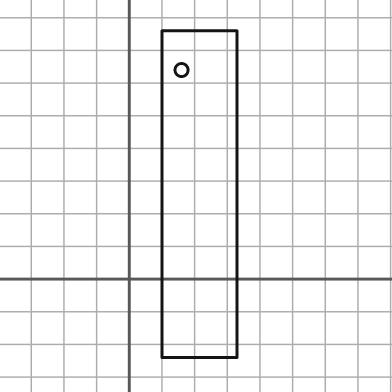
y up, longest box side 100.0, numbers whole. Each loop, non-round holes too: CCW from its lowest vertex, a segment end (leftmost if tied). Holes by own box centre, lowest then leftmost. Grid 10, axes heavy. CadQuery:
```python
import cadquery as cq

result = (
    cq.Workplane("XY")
    .moveTo(10.0, -24.0)
    .lineTo(33.0, -24.0)
    .lineTo(33.0, 76.0)
    .lineTo(10.0, 76.0)
    .close()
    .moveTo(16.0, 64.0)
    .circle(2.0)
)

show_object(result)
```